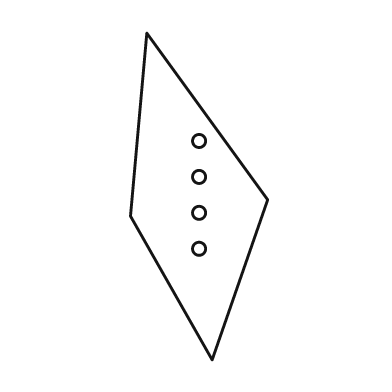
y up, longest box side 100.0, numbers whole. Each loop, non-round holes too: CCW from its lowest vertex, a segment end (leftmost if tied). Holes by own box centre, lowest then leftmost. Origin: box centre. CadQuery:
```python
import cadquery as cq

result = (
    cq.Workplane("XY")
    .moveTo(4.0, -50.0)
    .lineTo(21.0, -1.0)
    .lineTo(-16.0, 50.0)
    .lineTo(-21.0, -6.0)
    .close()
    .moveTo(0.0, -16.0)
    .circle(2.0)
    .moveTo(0.0, -5.0)
    .circle(2.0)
    .moveTo(0.0, 6.0)
    .circle(2.0)
    .moveTo(0.0, 17.0)
    .circle(2.0)
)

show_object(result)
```